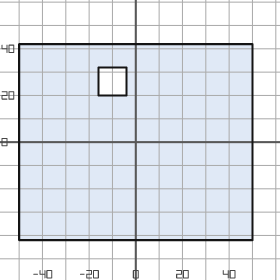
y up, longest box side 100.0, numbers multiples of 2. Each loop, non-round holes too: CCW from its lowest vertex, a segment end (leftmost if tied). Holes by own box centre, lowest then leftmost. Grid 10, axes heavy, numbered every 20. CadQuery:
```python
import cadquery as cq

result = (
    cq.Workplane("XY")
    .moveTo(-50.0, -42.0)
    .lineTo(50.0, -42.0)
    .lineTo(50.0, 42.0)
    .lineTo(-50.0, 42.0)
    .close()
    .moveTo(-16.0, 20.0)
    .lineTo(-4.0, 20.0)
    .lineTo(-4.0, 32.0)
    .lineTo(-16.0, 32.0)
    .close()
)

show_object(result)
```